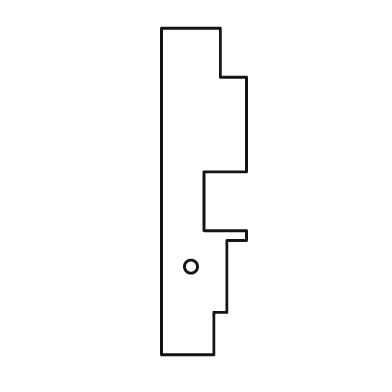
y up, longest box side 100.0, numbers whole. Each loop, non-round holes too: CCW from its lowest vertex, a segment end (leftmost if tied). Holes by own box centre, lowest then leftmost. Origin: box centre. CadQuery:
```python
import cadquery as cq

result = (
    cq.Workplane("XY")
    .moveTo(-13.0, -50.0)
    .lineTo(3.0, -50.0)
    .lineTo(3.0, -37.0)
    .lineTo(7.0, -37.0)
    .lineTo(7.0, -15.0)
    .lineTo(13.0, -15.0)
    .lineTo(13.0, -12.0)
    .lineTo(0.0, -12.0)
    .lineTo(0.0, 6.0)
    .lineTo(13.0, 6.0)
    .lineTo(13.0, 35.0)
    .lineTo(5.0, 35.0)
    .lineTo(5.0, 50.0)
    .lineTo(-13.0, 50.0)
    .close()
    .moveTo(-4.0, -23.0)
    .circle(2.0)
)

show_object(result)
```